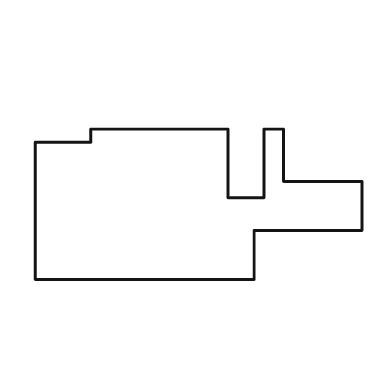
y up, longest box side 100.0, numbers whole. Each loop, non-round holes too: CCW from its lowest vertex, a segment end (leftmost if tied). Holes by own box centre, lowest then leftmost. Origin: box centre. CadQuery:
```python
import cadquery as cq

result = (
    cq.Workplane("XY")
    .moveTo(-50.0, -23.0)
    .lineTo(17.0, -23.0)
    .lineTo(17.0, -8.0)
    .lineTo(50.0, -8.0)
    .lineTo(50.0, 7.0)
    .lineTo(26.0, 7.0)
    .lineTo(26.0, 23.0)
    .lineTo(20.0, 23.0)
    .lineTo(20.0, 2.0)
    .lineTo(9.0, 2.0)
    .lineTo(9.0, 23.0)
    .lineTo(-33.0, 23.0)
    .lineTo(-33.0, 19.0)
    .lineTo(-50.0, 19.0)
    .close()
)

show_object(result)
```